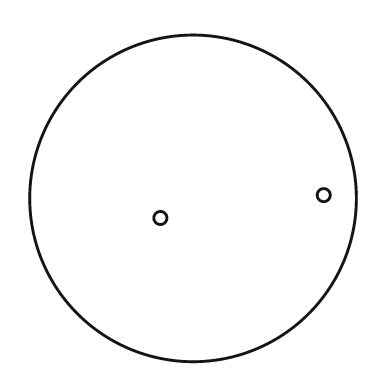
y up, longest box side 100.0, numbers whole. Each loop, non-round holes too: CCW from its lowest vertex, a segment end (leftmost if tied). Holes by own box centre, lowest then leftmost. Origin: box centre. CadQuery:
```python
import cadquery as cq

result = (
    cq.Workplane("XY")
    .moveTo(0.0, 0.0)
    .circle(50.0)
    .moveTo(-10.0, -6.0)
    .circle(2.0)
    .moveTo(40.0, 1.0)
    .circle(2.0)
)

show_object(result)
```